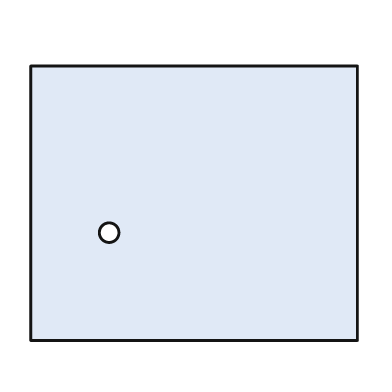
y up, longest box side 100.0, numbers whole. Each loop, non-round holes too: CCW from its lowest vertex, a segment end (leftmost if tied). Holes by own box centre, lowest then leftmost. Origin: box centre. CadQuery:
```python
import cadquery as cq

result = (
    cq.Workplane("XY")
    .moveTo(-50.0, -42.0)
    .lineTo(50.0, -42.0)
    .lineTo(50.0, 42.0)
    .lineTo(-50.0, 42.0)
    .close()
    .moveTo(-26.0, -9.0)
    .circle(3.0)
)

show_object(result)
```